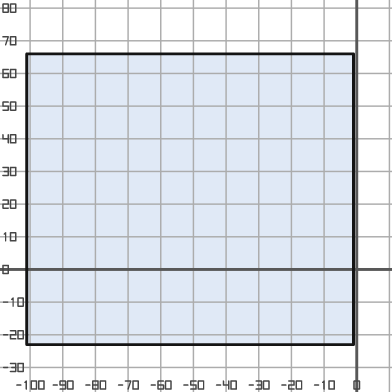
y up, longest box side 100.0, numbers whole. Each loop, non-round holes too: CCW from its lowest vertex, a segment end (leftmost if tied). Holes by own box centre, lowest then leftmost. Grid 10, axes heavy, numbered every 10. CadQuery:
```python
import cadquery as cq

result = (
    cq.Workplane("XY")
    .moveTo(-101.0, -23.0)
    .lineTo(-1.0, -23.0)
    .lineTo(-1.0, 66.0)
    .lineTo(-101.0, 66.0)
    .close()
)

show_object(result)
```